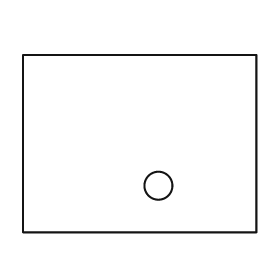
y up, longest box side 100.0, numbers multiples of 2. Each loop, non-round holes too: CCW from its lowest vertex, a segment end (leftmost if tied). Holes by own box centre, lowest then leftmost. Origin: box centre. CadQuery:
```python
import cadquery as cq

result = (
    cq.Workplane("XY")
    .moveTo(-50.0, -38.0)
    .lineTo(50.0, -38.0)
    .lineTo(50.0, 38.0)
    .lineTo(-50.0, 38.0)
    .close()
    .moveTo(8.0, -18.0)
    .circle(6.0)
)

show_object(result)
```